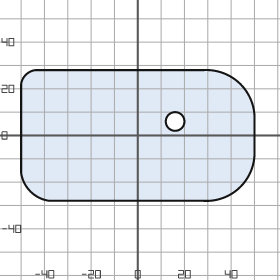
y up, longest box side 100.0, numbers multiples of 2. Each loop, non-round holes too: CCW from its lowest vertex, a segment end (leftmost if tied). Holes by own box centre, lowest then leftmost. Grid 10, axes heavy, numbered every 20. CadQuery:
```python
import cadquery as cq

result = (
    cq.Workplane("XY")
    .moveTo(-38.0, -28.0)
    .lineTo(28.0, -28.0)
    .threePointArc((44.0, -22.0), (50.0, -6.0))
    .lineTo(50.0, 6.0)
    .threePointArc((44.0, 22.0), (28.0, 28.0))
    .lineTo(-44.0, 28.0)
    .threePointArc((-48.0, 26.0), (-50.0, 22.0))
    .lineTo(-50.0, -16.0)
    .threePointArc((-46.0, -24.0), (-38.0, -28.0))
    .close()
    .moveTo(16.0, 6.0)
    .circle(4.0)
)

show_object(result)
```